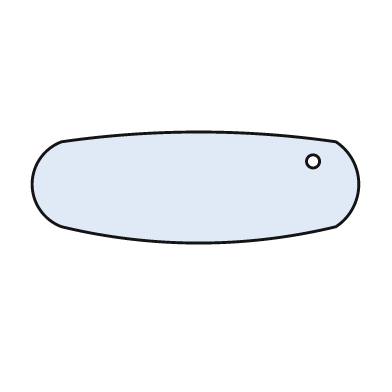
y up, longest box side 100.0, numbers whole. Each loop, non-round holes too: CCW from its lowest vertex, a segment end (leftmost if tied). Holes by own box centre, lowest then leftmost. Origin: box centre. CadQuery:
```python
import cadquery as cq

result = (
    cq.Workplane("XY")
    .moveTo(-41.0, -12.0)
    .threePointArc((1.0, -17.0), (43.0, -12.0))
    .threePointArc((50.0, 1.0), (43.0, 14.0))
    .threePointArc((1.0, 17.0), (-41.0, 14.0))
    .threePointArc((-50.0, 1.0), (-41.0, -12.0))
    .close()
    .moveTo(36.0, 8.0)
    .circle(2.0)
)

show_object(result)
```